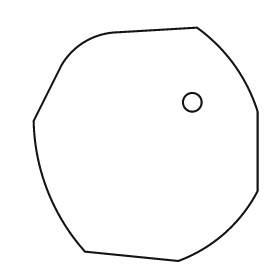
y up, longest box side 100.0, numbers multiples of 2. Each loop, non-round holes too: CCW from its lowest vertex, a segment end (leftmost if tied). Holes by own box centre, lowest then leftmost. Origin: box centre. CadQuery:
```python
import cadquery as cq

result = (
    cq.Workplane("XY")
    .moveTo(14.0, -50.0)
    .threePointArc((34.0, -38.0), (48.0, -20.0))
    .lineTo(48.0, 14.0)
    .threePointArc((38.0, 34.0), (22.0, 50.0))
    .lineTo(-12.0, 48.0)
    .threePointArc((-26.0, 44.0), (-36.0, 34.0))
    .lineTo(-48.0, 10.0)
    .threePointArc((-42.0, -20.0), (-26.0, -46.0))
    .close()
    .moveTo(20.0, 18.0)
    .circle(4.0)
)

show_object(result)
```